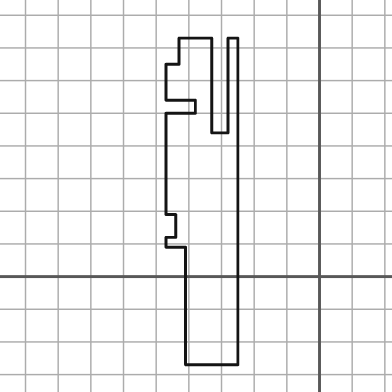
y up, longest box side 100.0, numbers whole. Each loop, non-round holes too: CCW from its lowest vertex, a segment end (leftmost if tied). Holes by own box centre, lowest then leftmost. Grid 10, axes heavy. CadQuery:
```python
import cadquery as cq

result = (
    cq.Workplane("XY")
    .moveTo(-41.0, -27.0)
    .lineTo(-25.0, -27.0)
    .lineTo(-25.0, 73.0)
    .lineTo(-28.0, 73.0)
    .lineTo(-28.0, 44.0)
    .lineTo(-33.0, 44.0)
    .lineTo(-33.0, 73.0)
    .lineTo(-43.0, 73.0)
    .lineTo(-43.0, 65.0)
    .lineTo(-47.0, 65.0)
    .lineTo(-47.0, 54.0)
    .lineTo(-38.0, 54.0)
    .lineTo(-38.0, 50.0)
    .lineTo(-47.0, 50.0)
    .lineTo(-47.0, 19.0)
    .lineTo(-44.0, 19.0)
    .lineTo(-44.0, 12.0)
    .lineTo(-47.0, 12.0)
    .lineTo(-47.0, 9.0)
    .lineTo(-41.0, 9.0)
    .close()
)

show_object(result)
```